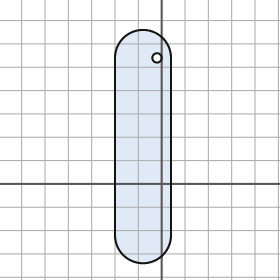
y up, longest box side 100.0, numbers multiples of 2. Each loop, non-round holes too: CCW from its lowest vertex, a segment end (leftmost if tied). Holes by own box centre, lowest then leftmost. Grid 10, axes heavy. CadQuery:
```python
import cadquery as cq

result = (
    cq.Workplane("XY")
    .moveTo(-20.0, -22.0)
    .threePointArc((-8.0, -34.0), (4.0, -22.0))
    .lineTo(4.0, 54.0)
    .threePointArc((-8.0, 66.0), (-20.0, 54.0))
    .close()
    .moveTo(-2.0, 54.0)
    .circle(2.0)
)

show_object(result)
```